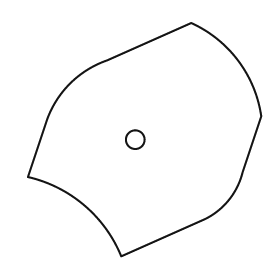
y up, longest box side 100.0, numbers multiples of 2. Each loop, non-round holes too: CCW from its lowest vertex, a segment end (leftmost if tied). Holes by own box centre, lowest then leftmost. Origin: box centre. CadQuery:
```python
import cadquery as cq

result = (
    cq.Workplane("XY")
    .moveTo(-10.0, -50.0)
    .lineTo(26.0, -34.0)
    .threePointArc((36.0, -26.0), (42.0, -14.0))
    .lineTo(50.0, 10.0)
    .threePointArc((40.0, 34.0), (20.0, 50.0))
    .lineTo(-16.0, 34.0)
    .threePointArc((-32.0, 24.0), (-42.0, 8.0))
    .lineTo(-50.0, -16.0)
    .threePointArc((-26.0, -28.0), (-10.0, -50.0))
    .close()
    .moveTo(-4.0, 0.0)
    .circle(4.0)
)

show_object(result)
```